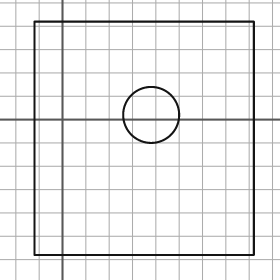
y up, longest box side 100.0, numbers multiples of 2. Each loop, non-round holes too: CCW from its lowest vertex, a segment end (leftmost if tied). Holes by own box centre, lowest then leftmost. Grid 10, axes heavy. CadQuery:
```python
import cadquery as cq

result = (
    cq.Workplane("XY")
    .moveTo(-12.0, -58.0)
    .lineTo(82.0, -58.0)
    .lineTo(82.0, 42.0)
    .lineTo(-12.0, 42.0)
    .close()
    .moveTo(38.0, 2.0)
    .circle(12.0)
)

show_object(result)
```